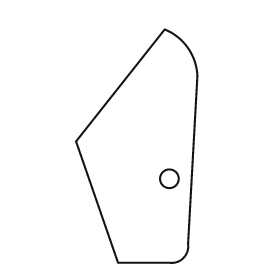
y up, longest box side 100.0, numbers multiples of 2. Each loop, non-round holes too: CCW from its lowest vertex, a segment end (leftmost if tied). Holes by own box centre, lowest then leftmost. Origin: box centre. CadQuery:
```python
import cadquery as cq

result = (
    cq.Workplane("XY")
    .moveTo(-8.0, -50.0)
    .lineTo(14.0, -50.0)
    .threePointArc((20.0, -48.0), (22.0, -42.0))
    .lineTo(26.0, 30.0)
    .threePointArc((22.0, 42.0), (12.0, 50.0))
    .lineTo(-26.0, 2.0)
    .close()
    .moveTo(14.0, -14.0)
    .circle(4.0)
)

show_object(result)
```